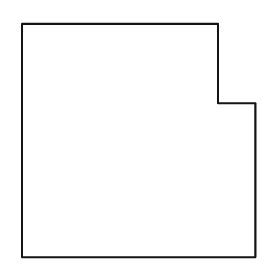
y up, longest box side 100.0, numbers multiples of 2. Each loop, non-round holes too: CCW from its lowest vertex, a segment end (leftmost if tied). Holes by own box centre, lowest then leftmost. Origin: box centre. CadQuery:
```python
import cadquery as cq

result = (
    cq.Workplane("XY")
    .moveTo(-50.0, -50.0)
    .lineTo(50.0, -50.0)
    .lineTo(50.0, 16.0)
    .lineTo(34.0, 16.0)
    .lineTo(34.0, 50.0)
    .lineTo(-50.0, 50.0)
    .close()
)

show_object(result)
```